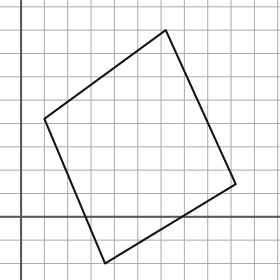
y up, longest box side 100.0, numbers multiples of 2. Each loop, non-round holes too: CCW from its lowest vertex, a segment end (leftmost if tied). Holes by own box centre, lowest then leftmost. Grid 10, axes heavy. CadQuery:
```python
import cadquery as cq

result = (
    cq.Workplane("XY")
    .moveTo(36.0, -20.0)
    .lineTo(92.0, 14.0)
    .lineTo(62.0, 80.0)
    .lineTo(10.0, 42.0)
    .close()
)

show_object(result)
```